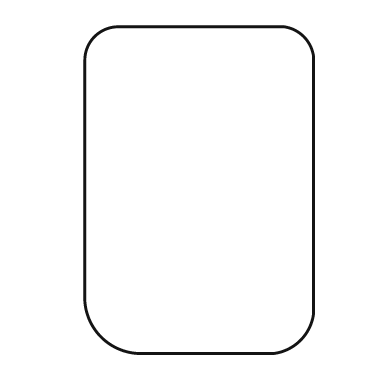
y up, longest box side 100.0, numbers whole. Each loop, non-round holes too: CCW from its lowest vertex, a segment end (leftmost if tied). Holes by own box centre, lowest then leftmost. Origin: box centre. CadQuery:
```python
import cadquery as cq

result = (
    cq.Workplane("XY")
    .moveTo(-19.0, -50.0)
    .lineTo(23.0, -50.0)
    .threePointArc((31.0, -46.0), (35.0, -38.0))
    .lineTo(35.0, 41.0)
    .threePointArc((32.0, 47.0), (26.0, 50.0))
    .lineTo(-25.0, 50.0)
    .threePointArc((-32.0, 47.0), (-35.0, 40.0))
    .lineTo(-35.0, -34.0)
    .threePointArc((-30.0, -45.0), (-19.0, -50.0))
    .close()
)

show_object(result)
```